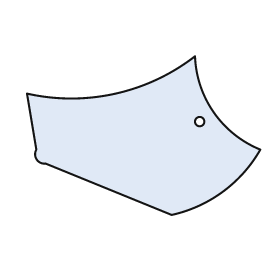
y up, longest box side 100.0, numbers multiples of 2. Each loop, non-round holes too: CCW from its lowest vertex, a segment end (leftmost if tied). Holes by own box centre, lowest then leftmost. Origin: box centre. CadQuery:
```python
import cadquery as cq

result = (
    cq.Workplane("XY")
    .moveTo(12.0, -34.0)
    .threePointArc((34.0, -24.0), (50.0, -6.0))
    .threePointArc((30.0, 10.0), (22.0, 34.0))
    .threePointArc((-12.0, 18.0), (-50.0, 18.0))
    .lineTo(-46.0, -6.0)
    .threePointArc((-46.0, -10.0), (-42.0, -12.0))
    .close()
    .moveTo(24.0, 6.0)
    .circle(2.0)
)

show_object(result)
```